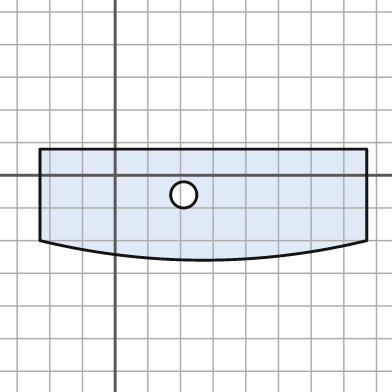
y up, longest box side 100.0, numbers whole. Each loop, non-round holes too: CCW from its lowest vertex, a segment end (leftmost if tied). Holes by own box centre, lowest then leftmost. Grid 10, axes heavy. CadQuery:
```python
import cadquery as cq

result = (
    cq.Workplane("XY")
    .moveTo(-23.0, -20.0)
    .threePointArc((27.0, -26.0), (77.0, -20.0))
    .lineTo(77.0, 8.0)
    .lineTo(-23.0, 8.0)
    .close()
    .moveTo(21.0, -6.0)
    .circle(4.0)
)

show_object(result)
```